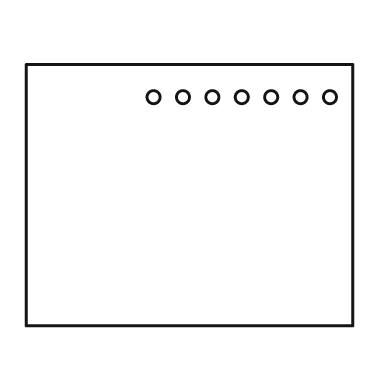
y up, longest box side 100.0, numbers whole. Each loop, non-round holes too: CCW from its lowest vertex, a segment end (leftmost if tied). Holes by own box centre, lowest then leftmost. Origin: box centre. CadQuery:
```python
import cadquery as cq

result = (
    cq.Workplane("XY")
    .moveTo(-50.0, -40.0)
    .lineTo(50.0, -40.0)
    .lineTo(50.0, 40.0)
    .lineTo(-50.0, 40.0)
    .close()
    .moveTo(-11.0, 30.0)
    .circle(2.0)
    .moveTo(-2.0, 30.0)
    .circle(2.0)
    .moveTo(7.0, 30.0)
    .circle(2.0)
    .moveTo(16.0, 30.0)
    .circle(2.0)
    .moveTo(25.0, 30.0)
    .circle(2.0)
    .moveTo(34.0, 30.0)
    .circle(2.0)
    .moveTo(43.0, 30.0)
    .circle(2.0)
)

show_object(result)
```